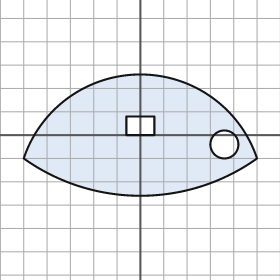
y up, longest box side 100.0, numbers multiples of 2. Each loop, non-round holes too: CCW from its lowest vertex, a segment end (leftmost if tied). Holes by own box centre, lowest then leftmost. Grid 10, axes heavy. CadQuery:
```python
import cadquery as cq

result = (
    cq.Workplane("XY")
    .moveTo(-50.0, -10.0)
    .threePointArc((0.0, -26.0), (50.0, -10.0))
    .threePointArc((0.0, 26.0), (-50.0, -10.0))
    .close()
    .moveTo(36.0, -4.0)
    .circle(6.0)
    .moveTo(-6.0, 0.0)
    .lineTo(6.0, 0.0)
    .lineTo(6.0, 8.0)
    .lineTo(-6.0, 8.0)
    .close()
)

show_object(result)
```